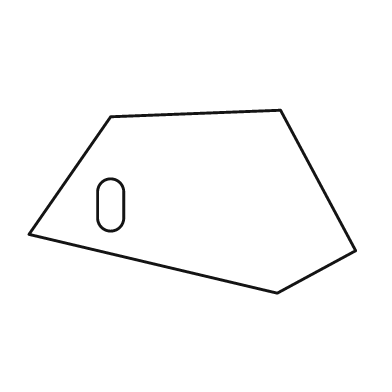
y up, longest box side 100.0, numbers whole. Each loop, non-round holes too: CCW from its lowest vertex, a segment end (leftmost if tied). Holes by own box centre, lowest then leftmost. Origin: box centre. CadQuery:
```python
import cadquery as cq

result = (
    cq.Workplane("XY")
    .moveTo(26.0, -28.0)
    .lineTo(50.0, -15.0)
    .lineTo(27.0, 28.0)
    .lineTo(-25.0, 26.0)
    .lineTo(-50.0, -10.0)
    .close()
    .moveTo(-29.0, -5.0)
    .threePointArc((-25.0, -9.0), (-21.0, -5.0))
    .lineTo(-21.0, 3.0)
    .threePointArc((-25.0, 7.0), (-29.0, 3.0))
    .close()
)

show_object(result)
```